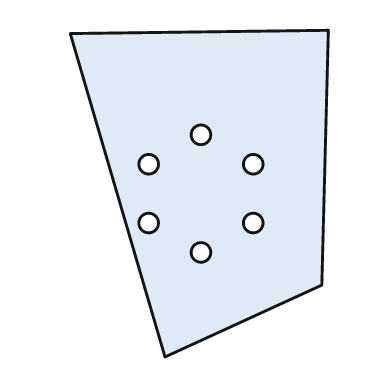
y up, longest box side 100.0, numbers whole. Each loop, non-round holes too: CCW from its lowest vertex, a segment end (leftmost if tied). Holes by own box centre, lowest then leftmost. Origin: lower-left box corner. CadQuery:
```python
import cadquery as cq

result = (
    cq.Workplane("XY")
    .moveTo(29.0, 0.0)
    .lineTo(77.0, 22.0)
    .lineTo(79.0, 100.0)
    .lineTo(0.0, 99.0)
    .close()
    .moveTo(40.0, 32.0)
    .circle(3.0)
    .moveTo(24.0, 41.0)
    .circle(3.0)
    .moveTo(56.0, 41.0)
    .circle(3.0)
    .moveTo(24.0, 59.0)
    .circle(3.0)
    .moveTo(56.0, 59.0)
    .circle(3.0)
    .moveTo(40.0, 68.0)
    .circle(3.0)
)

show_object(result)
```